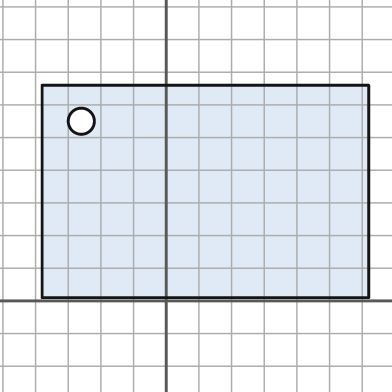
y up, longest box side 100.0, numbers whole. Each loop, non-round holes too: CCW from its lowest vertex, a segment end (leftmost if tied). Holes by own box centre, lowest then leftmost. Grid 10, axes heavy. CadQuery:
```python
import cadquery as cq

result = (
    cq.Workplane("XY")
    .moveTo(-38.0, 1.0)
    .lineTo(62.0, 1.0)
    .lineTo(62.0, 66.0)
    .lineTo(-38.0, 66.0)
    .close()
    .moveTo(-26.0, 55.0)
    .circle(4.0)
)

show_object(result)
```